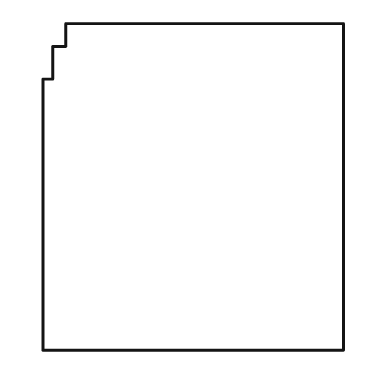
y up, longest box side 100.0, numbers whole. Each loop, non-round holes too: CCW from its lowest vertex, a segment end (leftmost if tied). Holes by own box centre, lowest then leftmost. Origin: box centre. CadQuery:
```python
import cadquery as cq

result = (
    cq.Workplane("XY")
    .moveTo(-46.0, -50.0)
    .lineTo(46.0, -50.0)
    .lineTo(46.0, 50.0)
    .lineTo(-39.0, 50.0)
    .lineTo(-39.0, 43.0)
    .lineTo(-43.0, 43.0)
    .lineTo(-43.0, 33.0)
    .lineTo(-46.0, 33.0)
    .close()
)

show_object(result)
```